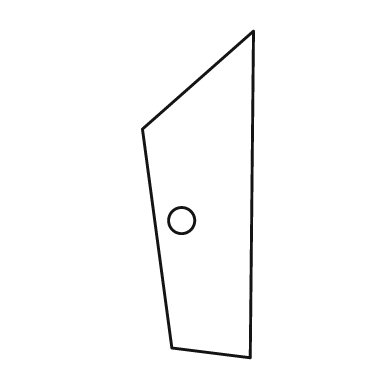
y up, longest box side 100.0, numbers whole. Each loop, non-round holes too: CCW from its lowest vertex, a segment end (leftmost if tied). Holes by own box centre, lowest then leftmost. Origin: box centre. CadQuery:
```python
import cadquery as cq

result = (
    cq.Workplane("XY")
    .moveTo(16.0, -50.0)
    .lineTo(17.0, 50.0)
    .lineTo(-17.0, 20.0)
    .lineTo(-8.0, -47.0)
    .close()
    .moveTo(-5.0, -8.0)
    .circle(4.0)
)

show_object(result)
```